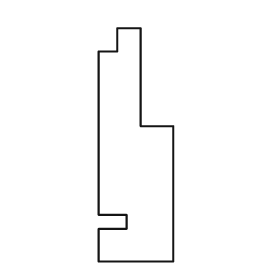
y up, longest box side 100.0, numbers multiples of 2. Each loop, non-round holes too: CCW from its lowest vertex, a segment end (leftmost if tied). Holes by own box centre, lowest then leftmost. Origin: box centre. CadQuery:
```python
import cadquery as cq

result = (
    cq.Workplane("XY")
    .moveTo(-16.0, -50.0)
    .lineTo(16.0, -50.0)
    .lineTo(16.0, 8.0)
    .lineTo(2.0, 8.0)
    .lineTo(2.0, 50.0)
    .lineTo(-8.0, 50.0)
    .lineTo(-8.0, 40.0)
    .lineTo(-16.0, 40.0)
    .lineTo(-16.0, -30.0)
    .lineTo(-4.0, -30.0)
    .lineTo(-4.0, -36.0)
    .lineTo(-16.0, -36.0)
    .close()
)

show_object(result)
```